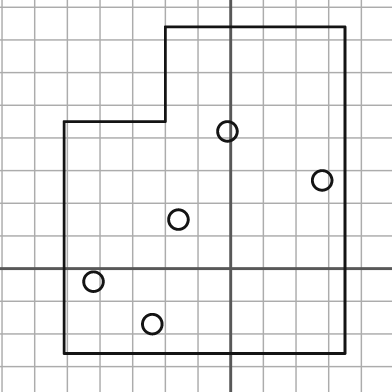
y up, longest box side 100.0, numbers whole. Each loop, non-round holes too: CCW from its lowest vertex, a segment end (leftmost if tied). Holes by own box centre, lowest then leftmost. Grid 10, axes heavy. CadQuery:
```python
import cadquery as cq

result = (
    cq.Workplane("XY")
    .moveTo(-51.0, -26.0)
    .lineTo(35.0, -26.0)
    .lineTo(35.0, 74.0)
    .lineTo(-20.0, 74.0)
    .lineTo(-20.0, 45.0)
    .lineTo(-51.0, 45.0)
    .close()
    .moveTo(-24.0, -17.0)
    .circle(3.0)
    .moveTo(-42.0, -4.0)
    .circle(3.0)
    .moveTo(-16.0, 15.0)
    .circle(3.0)
    .moveTo(28.0, 27.0)
    .circle(3.0)
    .moveTo(-1.0, 42.0)
    .circle(3.0)
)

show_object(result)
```